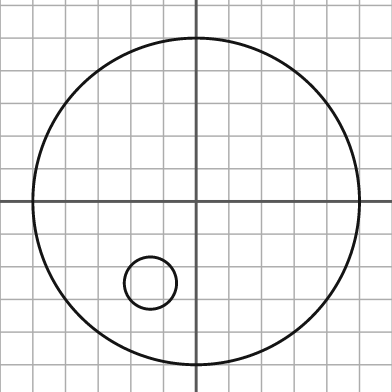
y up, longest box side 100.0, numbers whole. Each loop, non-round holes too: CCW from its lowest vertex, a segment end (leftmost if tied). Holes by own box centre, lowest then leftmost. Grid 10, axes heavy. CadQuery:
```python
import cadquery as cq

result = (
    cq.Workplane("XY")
    .moveTo(0.0, 0.0)
    .circle(50.0)
    .moveTo(-14.0, -25.0)
    .circle(8.0)
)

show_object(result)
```